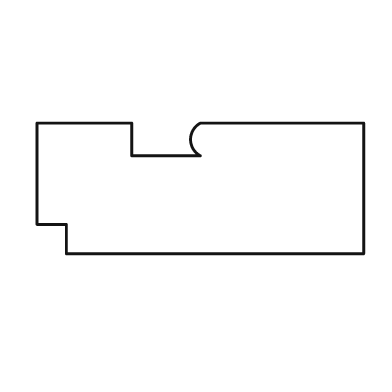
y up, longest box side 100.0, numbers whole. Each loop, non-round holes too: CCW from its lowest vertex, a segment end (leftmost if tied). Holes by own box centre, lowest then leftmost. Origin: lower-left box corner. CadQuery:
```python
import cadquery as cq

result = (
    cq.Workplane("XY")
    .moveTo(9.0, 0.0)
    .lineTo(100.0, 0.0)
    .lineTo(100.0, 40.0)
    .lineTo(50.0, 40.0)
    .threePointArc((47.0, 35.0), (50.0, 30.0))
    .lineTo(29.0, 30.0)
    .lineTo(29.0, 40.0)
    .lineTo(0.0, 40.0)
    .lineTo(0.0, 9.0)
    .lineTo(9.0, 9.0)
    .close()
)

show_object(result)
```